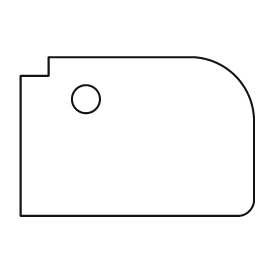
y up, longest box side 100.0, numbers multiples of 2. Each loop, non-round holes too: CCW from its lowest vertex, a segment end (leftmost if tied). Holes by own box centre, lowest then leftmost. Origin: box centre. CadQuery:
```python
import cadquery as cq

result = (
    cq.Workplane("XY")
    .moveTo(-50.0, -34.0)
    .lineTo(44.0, -34.0)
    .threePointArc((48.0, -32.0), (50.0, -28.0))
    .lineTo(50.0, 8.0)
    .threePointArc((42.0, 26.0), (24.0, 34.0))
    .lineTo(-38.0, 34.0)
    .lineTo(-38.0, 26.0)
    .lineTo(-50.0, 26.0)
    .close()
    .moveTo(-22.0, 16.0)
    .circle(6.0)
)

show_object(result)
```